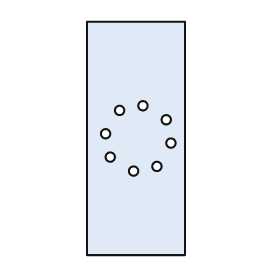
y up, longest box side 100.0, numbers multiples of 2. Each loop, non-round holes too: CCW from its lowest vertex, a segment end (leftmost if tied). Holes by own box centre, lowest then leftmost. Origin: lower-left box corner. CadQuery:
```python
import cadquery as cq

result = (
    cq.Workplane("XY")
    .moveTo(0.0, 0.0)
    .lineTo(42.0, 0.0)
    .lineTo(42.0, 100.0)
    .lineTo(0.0, 100.0)
    .close()
    .moveTo(20.0, 36.0)
    .circle(2.0)
    .moveTo(30.0, 38.0)
    .circle(2.0)
    .moveTo(10.0, 42.0)
    .circle(2.0)
    .moveTo(36.0, 48.0)
    .circle(2.0)
    .moveTo(8.0, 52.0)
    .circle(2.0)
    .moveTo(34.0, 58.0)
    .circle(2.0)
    .moveTo(14.0, 62.0)
    .circle(2.0)
    .moveTo(24.0, 64.0)
    .circle(2.0)
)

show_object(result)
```